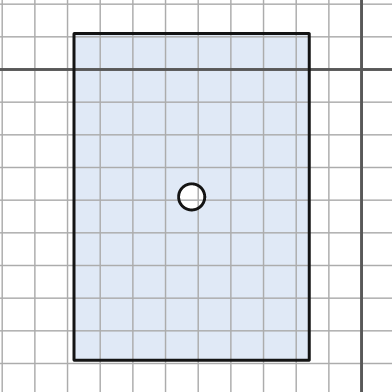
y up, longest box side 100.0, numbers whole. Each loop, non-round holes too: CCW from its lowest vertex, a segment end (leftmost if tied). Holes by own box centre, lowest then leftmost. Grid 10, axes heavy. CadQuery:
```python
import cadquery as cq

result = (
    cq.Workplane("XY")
    .moveTo(-88.0, -89.0)
    .lineTo(-16.0, -89.0)
    .lineTo(-16.0, 11.0)
    .lineTo(-88.0, 11.0)
    .close()
    .moveTo(-52.0, -39.0)
    .circle(4.0)
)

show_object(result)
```